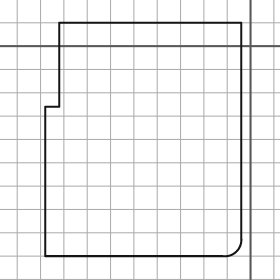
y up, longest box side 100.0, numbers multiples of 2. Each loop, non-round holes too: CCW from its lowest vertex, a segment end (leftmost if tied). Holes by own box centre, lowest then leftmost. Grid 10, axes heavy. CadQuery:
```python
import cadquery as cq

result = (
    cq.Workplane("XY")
    .moveTo(-88.0, -90.0)
    .lineTo(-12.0, -90.0)
    .threePointArc((-6.0, -88.0), (-4.0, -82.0))
    .lineTo(-4.0, 10.0)
    .lineTo(-82.0, 10.0)
    .lineTo(-82.0, -26.0)
    .lineTo(-88.0, -26.0)
    .close()
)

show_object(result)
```